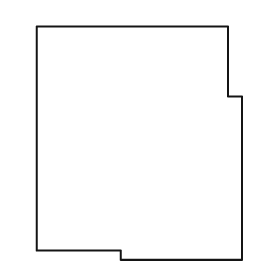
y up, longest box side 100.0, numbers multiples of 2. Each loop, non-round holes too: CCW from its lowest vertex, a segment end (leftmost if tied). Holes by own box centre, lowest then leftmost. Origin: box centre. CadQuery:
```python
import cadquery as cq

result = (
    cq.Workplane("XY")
    .moveTo(-8.0, -50.0)
    .lineTo(44.0, -50.0)
    .lineTo(44.0, 20.0)
    .lineTo(38.0, 20.0)
    .lineTo(38.0, 50.0)
    .lineTo(-44.0, 50.0)
    .lineTo(-44.0, -46.0)
    .lineTo(-8.0, -46.0)
    .close()
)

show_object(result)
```